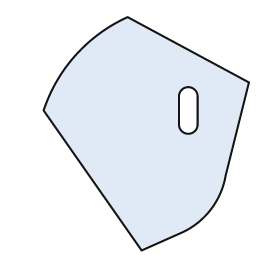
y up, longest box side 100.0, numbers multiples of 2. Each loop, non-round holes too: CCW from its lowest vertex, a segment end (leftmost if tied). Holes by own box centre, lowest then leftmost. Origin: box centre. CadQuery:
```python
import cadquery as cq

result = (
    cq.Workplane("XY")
    .moveTo(-2.0, -50.0)
    .lineTo(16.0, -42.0)
    .threePointArc((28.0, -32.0), (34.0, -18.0))
    .lineTo(44.0, 22.0)
    .lineTo(-8.0, 50.0)
    .threePointArc((-30.0, 34.0), (-44.0, 10.0))
    .close()
    .moveTo(14.0, 4.0)
    .threePointArc((18.0, 0.0), (22.0, 4.0))
    .lineTo(22.0, 16.0)
    .threePointArc((18.0, 20.0), (14.0, 16.0))
    .close()
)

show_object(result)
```